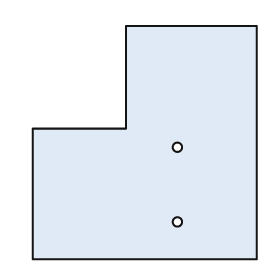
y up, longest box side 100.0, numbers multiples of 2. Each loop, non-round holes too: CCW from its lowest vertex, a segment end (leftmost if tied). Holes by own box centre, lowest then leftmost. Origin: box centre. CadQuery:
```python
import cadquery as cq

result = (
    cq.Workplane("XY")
    .moveTo(-48.0, -50.0)
    .lineTo(48.0, -50.0)
    .lineTo(48.0, 50.0)
    .lineTo(-8.0, 50.0)
    .lineTo(-8.0, 6.0)
    .lineTo(-48.0, 6.0)
    .close()
    .moveTo(14.0, -34.0)
    .circle(2.0)
    .moveTo(14.0, -2.0)
    .circle(2.0)
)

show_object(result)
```